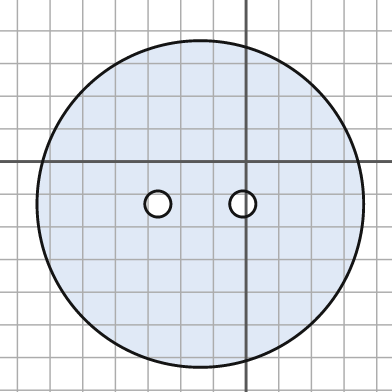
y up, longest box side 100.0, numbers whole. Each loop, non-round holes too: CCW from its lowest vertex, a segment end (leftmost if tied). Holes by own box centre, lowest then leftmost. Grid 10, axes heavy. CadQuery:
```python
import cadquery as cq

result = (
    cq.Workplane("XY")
    .moveTo(-14.0, -13.0)
    .circle(50.0)
    .moveTo(-27.0, -13.0)
    .circle(4.0)
    .moveTo(-1.0, -13.0)
    .circle(4.0)
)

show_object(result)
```